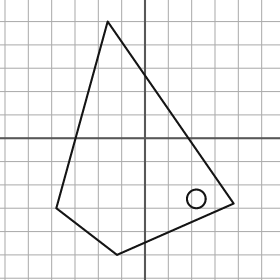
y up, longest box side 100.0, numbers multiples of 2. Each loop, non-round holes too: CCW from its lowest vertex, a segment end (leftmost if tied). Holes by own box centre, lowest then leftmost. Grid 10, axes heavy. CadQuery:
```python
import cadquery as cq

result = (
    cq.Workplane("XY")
    .moveTo(-12.0, -50.0)
    .lineTo(38.0, -28.0)
    .lineTo(-16.0, 50.0)
    .lineTo(-38.0, -30.0)
    .close()
    .moveTo(22.0, -26.0)
    .circle(4.0)
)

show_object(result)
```